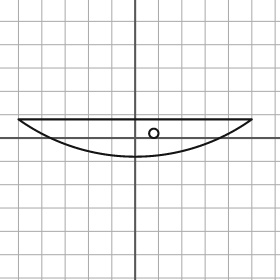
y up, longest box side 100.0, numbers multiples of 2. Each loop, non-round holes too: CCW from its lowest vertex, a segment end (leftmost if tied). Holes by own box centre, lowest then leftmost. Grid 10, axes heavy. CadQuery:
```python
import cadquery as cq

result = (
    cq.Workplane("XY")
    .moveTo(-50.0, 8.0)
    .threePointArc((0.0, -8.0), (50.0, 8.0))
    .close()
    .moveTo(8.0, 2.0)
    .circle(2.0)
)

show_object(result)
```